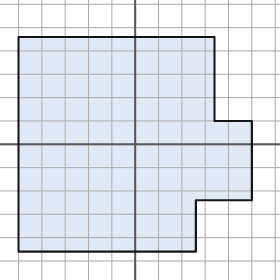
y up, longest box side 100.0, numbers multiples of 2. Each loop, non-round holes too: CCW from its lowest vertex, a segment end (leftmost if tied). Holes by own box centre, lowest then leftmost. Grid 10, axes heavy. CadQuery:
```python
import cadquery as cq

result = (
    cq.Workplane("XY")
    .moveTo(-50.0, -46.0)
    .lineTo(26.0, -46.0)
    .lineTo(26.0, -24.0)
    .lineTo(50.0, -24.0)
    .lineTo(50.0, 10.0)
    .lineTo(34.0, 10.0)
    .lineTo(34.0, 46.0)
    .lineTo(-50.0, 46.0)
    .close()
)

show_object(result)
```